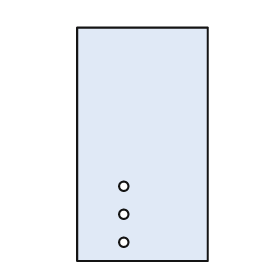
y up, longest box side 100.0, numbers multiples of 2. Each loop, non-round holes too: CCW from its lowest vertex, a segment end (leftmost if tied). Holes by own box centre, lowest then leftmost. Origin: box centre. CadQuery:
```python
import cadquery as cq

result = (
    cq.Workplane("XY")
    .moveTo(-28.0, -50.0)
    .lineTo(28.0, -50.0)
    .lineTo(28.0, 50.0)
    .lineTo(-28.0, 50.0)
    .close()
    .moveTo(-8.0, -42.0)
    .circle(2.0)
    .moveTo(-8.0, -30.0)
    .circle(2.0)
    .moveTo(-8.0, -18.0)
    .circle(2.0)
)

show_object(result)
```